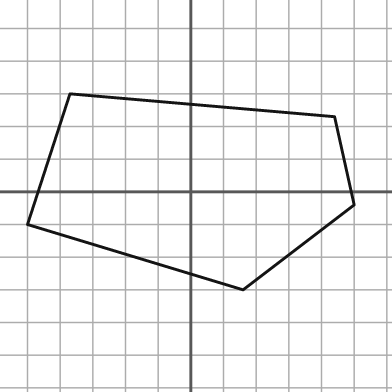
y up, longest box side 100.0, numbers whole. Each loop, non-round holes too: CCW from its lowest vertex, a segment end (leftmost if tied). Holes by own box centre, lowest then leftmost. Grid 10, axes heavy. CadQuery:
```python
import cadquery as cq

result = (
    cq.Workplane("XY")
    .moveTo(16.0, -30.0)
    .lineTo(50.0, -4.0)
    .lineTo(44.0, 23.0)
    .lineTo(-37.0, 30.0)
    .lineTo(-50.0, -10.0)
    .close()
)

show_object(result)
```